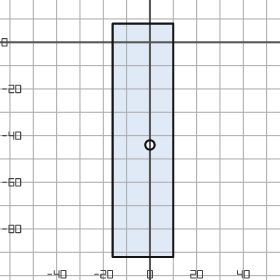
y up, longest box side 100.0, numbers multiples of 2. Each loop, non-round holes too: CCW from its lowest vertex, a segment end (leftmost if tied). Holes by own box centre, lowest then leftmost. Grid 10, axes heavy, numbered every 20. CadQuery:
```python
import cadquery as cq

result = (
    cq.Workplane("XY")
    .moveTo(-16.0, -92.0)
    .lineTo(10.0, -92.0)
    .lineTo(10.0, 8.0)
    .lineTo(-16.0, 8.0)
    .close()
    .moveTo(0.0, -44.0)
    .circle(2.0)
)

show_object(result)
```